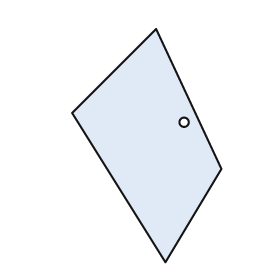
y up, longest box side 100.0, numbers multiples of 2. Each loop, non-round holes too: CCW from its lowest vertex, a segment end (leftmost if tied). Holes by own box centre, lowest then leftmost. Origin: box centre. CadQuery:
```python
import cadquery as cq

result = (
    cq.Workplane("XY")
    .moveTo(8.0, -50.0)
    .lineTo(32.0, -10.0)
    .lineTo(4.0, 50.0)
    .lineTo(-32.0, 14.0)
    .close()
    .moveTo(16.0, 10.0)
    .circle(2.0)
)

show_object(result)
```